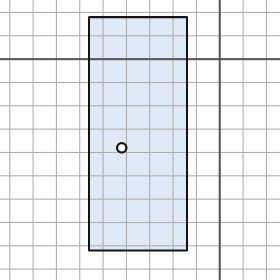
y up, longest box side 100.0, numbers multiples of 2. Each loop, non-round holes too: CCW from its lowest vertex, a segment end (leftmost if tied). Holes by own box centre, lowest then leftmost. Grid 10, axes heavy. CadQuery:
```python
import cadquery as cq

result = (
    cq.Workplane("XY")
    .moveTo(-56.0, -82.0)
    .lineTo(-14.0, -82.0)
    .lineTo(-14.0, 18.0)
    .lineTo(-56.0, 18.0)
    .close()
    .moveTo(-42.0, -38.0)
    .circle(2.0)
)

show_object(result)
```